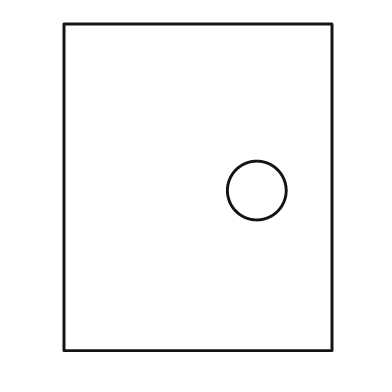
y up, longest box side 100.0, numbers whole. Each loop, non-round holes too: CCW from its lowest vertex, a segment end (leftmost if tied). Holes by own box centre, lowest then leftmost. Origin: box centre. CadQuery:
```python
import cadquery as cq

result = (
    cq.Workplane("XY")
    .moveTo(-41.0, -50.0)
    .lineTo(41.0, -50.0)
    .lineTo(41.0, 50.0)
    .lineTo(-41.0, 50.0)
    .close()
    .moveTo(18.0, -1.0)
    .circle(9.0)
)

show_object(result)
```